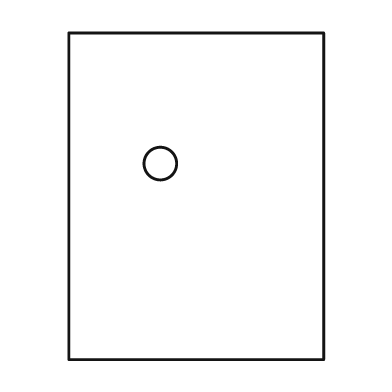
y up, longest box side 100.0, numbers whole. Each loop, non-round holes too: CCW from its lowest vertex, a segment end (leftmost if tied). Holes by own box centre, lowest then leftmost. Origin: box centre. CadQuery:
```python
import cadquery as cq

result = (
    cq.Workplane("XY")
    .moveTo(-39.0, -50.0)
    .lineTo(39.0, -50.0)
    .lineTo(39.0, 50.0)
    .lineTo(-39.0, 50.0)
    .close()
    .moveTo(-11.0, 10.0)
    .circle(5.0)
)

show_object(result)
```